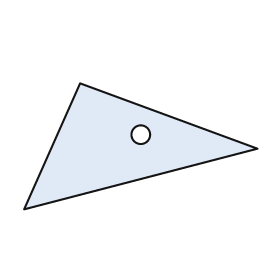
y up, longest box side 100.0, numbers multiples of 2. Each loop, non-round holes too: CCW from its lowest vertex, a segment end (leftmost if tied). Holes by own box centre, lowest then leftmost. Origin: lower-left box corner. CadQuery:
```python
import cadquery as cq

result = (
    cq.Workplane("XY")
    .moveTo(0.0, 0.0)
    .lineTo(100.0, 26.0)
    .lineTo(24.0, 54.0)
    .close()
    .moveTo(50.0, 32.0)
    .circle(4.0)
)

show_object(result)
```